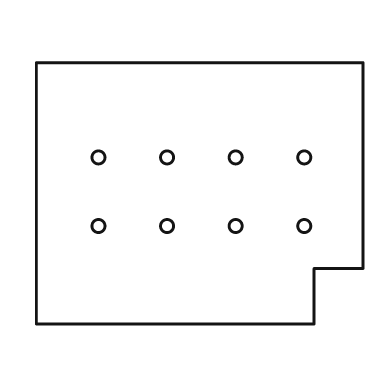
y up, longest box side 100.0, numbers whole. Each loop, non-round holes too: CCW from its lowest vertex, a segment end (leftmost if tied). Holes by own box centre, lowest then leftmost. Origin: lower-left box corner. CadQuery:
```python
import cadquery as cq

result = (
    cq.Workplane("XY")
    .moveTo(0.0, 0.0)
    .lineTo(85.0, 0.0)
    .lineTo(85.0, 17.0)
    .lineTo(100.0, 17.0)
    .lineTo(100.0, 80.0)
    .lineTo(0.0, 80.0)
    .close()
    .moveTo(19.0, 30.0)
    .circle(2.0)
    .moveTo(40.0, 30.0)
    .circle(2.0)
    .moveTo(61.0, 30.0)
    .circle(2.0)
    .moveTo(82.0, 30.0)
    .circle(2.0)
    .moveTo(19.0, 51.0)
    .circle(2.0)
    .moveTo(40.0, 51.0)
    .circle(2.0)
    .moveTo(61.0, 51.0)
    .circle(2.0)
    .moveTo(82.0, 51.0)
    .circle(2.0)
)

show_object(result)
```